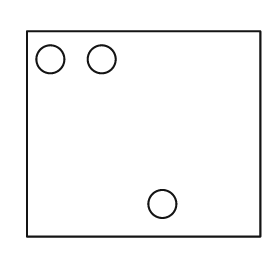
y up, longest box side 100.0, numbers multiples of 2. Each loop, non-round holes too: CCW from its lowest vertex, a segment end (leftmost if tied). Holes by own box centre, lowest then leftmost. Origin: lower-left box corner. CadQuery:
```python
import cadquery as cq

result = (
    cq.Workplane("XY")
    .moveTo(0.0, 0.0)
    .lineTo(100.0, 0.0)
    .lineTo(100.0, 88.0)
    .lineTo(0.0, 88.0)
    .close()
    .moveTo(58.0, 14.0)
    .circle(6.0)
    .moveTo(10.0, 76.0)
    .circle(6.0)
    .moveTo(32.0, 76.0)
    .circle(6.0)
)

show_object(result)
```